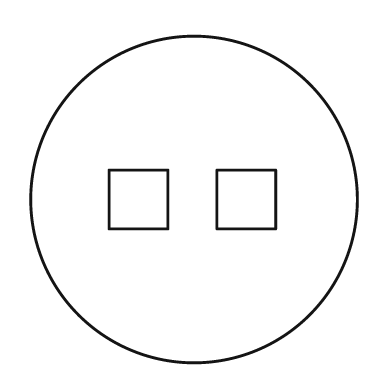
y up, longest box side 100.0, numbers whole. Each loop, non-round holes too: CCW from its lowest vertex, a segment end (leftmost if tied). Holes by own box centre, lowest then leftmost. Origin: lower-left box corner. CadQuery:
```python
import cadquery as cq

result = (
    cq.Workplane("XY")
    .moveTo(50.0, 50.0)
    .circle(50.0)
    .moveTo(24.0, 41.0)
    .lineTo(42.0, 41.0)
    .lineTo(42.0, 59.0)
    .lineTo(24.0, 59.0)
    .close()
    .moveTo(57.0, 41.0)
    .lineTo(75.0, 41.0)
    .lineTo(75.0, 59.0)
    .lineTo(57.0, 59.0)
    .close()
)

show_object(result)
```